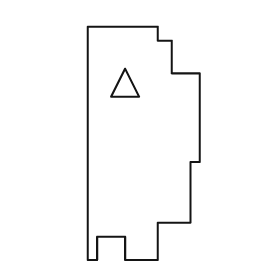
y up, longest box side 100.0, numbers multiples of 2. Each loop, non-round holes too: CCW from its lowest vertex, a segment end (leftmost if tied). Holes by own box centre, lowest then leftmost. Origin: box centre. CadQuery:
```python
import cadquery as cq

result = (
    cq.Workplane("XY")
    .moveTo(-24.0, -50.0)
    .lineTo(-20.0, -50.0)
    .lineTo(-20.0, -40.0)
    .lineTo(-8.0, -40.0)
    .lineTo(-8.0, -50.0)
    .lineTo(6.0, -50.0)
    .lineTo(6.0, -34.0)
    .lineTo(20.0, -34.0)
    .lineTo(20.0, -8.0)
    .lineTo(24.0, -8.0)
    .lineTo(24.0, 30.0)
    .lineTo(12.0, 30.0)
    .lineTo(12.0, 44.0)
    .lineTo(6.0, 44.0)
    .lineTo(6.0, 50.0)
    .lineTo(-24.0, 50.0)
    .close()
    .moveTo(-14.0, 20.0)
    .lineTo(-2.0, 20.0)
    .lineTo(-8.0, 32.0)
    .close()
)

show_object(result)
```